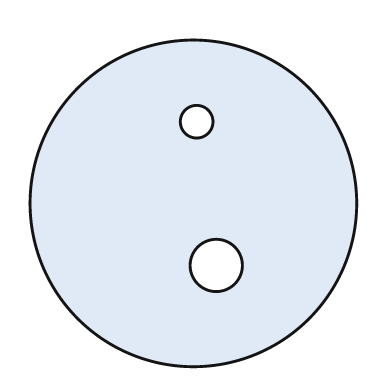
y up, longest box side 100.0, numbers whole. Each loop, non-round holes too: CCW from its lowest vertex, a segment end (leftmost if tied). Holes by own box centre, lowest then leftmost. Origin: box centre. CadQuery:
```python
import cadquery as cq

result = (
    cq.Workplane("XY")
    .moveTo(0.0, 0.0)
    .circle(50.0)
    .moveTo(7.0, -19.0)
    .circle(8.0)
    .moveTo(1.0, 25.0)
    .circle(5.0)
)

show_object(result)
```